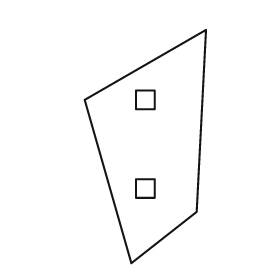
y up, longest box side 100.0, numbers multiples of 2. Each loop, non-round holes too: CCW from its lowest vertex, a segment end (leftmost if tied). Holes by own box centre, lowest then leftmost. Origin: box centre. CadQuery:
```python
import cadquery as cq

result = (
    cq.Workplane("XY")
    .moveTo(-6.0, -50.0)
    .lineTo(22.0, -28.0)
    .lineTo(26.0, 50.0)
    .lineTo(-26.0, 20.0)
    .close()
    .moveTo(-4.0, -22.0)
    .lineTo(4.0, -22.0)
    .lineTo(4.0, -14.0)
    .lineTo(-4.0, -14.0)
    .close()
    .moveTo(-4.0, 16.0)
    .lineTo(4.0, 16.0)
    .lineTo(4.0, 24.0)
    .lineTo(-4.0, 24.0)
    .close()
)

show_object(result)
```